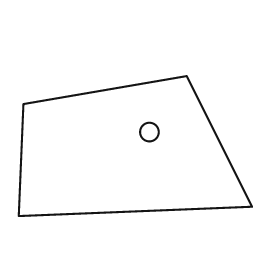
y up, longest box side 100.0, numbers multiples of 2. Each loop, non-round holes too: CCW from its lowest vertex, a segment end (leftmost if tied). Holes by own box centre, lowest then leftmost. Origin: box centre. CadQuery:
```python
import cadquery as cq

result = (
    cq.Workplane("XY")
    .moveTo(-50.0, -30.0)
    .lineTo(50.0, -26.0)
    .lineTo(22.0, 30.0)
    .lineTo(-48.0, 18.0)
    .close()
    .moveTo(6.0, 6.0)
    .circle(4.0)
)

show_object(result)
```